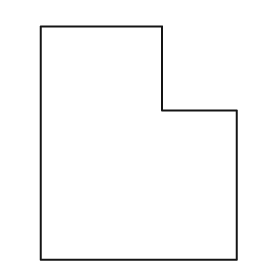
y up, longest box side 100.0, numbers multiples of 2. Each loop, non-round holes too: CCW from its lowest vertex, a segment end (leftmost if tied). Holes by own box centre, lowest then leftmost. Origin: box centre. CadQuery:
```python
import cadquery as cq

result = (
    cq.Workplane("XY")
    .moveTo(-42.0, -50.0)
    .lineTo(42.0, -50.0)
    .lineTo(42.0, 14.0)
    .lineTo(10.0, 14.0)
    .lineTo(10.0, 50.0)
    .lineTo(-42.0, 50.0)
    .close()
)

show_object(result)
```